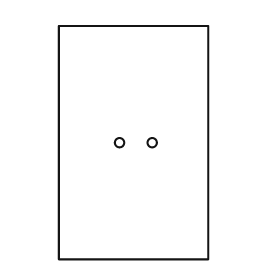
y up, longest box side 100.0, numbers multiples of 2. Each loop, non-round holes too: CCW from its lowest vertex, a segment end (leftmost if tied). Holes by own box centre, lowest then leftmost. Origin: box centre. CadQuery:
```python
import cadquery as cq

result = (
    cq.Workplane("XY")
    .moveTo(-32.0, -50.0)
    .lineTo(32.0, -50.0)
    .lineTo(32.0, 50.0)
    .lineTo(-32.0, 50.0)
    .close()
    .moveTo(-6.0, 0.0)
    .circle(2.0)
    .moveTo(8.0, 0.0)
    .circle(2.0)
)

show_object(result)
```